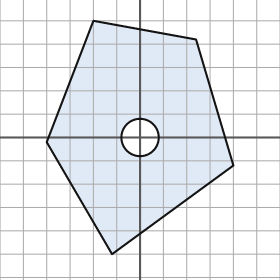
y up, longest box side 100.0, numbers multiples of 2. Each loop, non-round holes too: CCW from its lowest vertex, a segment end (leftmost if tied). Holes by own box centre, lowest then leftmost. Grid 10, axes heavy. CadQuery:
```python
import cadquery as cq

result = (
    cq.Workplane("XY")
    .moveTo(-12.0, -50.0)
    .lineTo(40.0, -12.0)
    .lineTo(24.0, 42.0)
    .lineTo(-20.0, 50.0)
    .lineTo(-40.0, -2.0)
    .close()
    .moveTo(0.0, 0.0)
    .circle(8.0)
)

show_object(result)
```